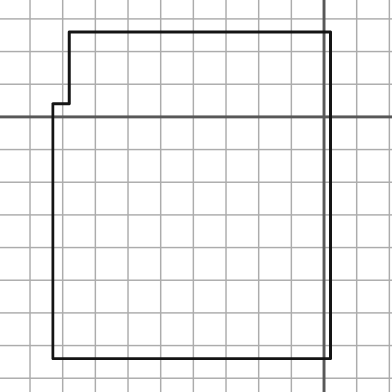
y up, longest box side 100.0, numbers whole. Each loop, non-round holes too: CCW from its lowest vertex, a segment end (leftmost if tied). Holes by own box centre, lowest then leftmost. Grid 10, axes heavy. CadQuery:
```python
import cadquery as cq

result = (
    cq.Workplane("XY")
    .moveTo(-83.0, -74.0)
    .lineTo(2.0, -74.0)
    .lineTo(2.0, 26.0)
    .lineTo(-78.0, 26.0)
    .lineTo(-78.0, 4.0)
    .lineTo(-83.0, 4.0)
    .close()
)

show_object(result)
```